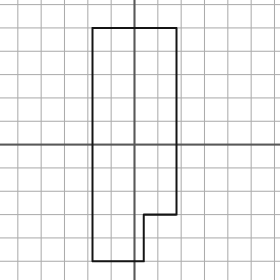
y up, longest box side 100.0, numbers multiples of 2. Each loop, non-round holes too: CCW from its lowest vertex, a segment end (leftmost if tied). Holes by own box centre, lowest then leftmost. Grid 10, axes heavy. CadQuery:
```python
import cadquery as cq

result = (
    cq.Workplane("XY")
    .moveTo(-18.0, -50.0)
    .lineTo(4.0, -50.0)
    .lineTo(4.0, -30.0)
    .lineTo(18.0, -30.0)
    .lineTo(18.0, 50.0)
    .lineTo(-18.0, 50.0)
    .close()
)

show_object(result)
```